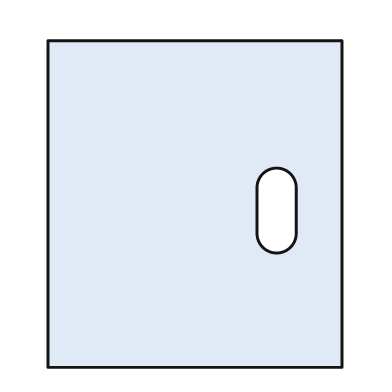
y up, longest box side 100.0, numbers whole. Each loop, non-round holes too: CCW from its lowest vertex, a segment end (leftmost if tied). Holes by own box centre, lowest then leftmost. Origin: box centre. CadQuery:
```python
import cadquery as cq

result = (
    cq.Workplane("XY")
    .moveTo(-45.0, -50.0)
    .lineTo(45.0, -50.0)
    .lineTo(45.0, 50.0)
    .lineTo(-45.0, 50.0)
    .close()
    .moveTo(19.0, -9.0)
    .threePointArc((25.0, -15.0), (31.0, -9.0))
    .lineTo(31.0, 5.0)
    .threePointArc((25.0, 11.0), (19.0, 5.0))
    .close()
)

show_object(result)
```